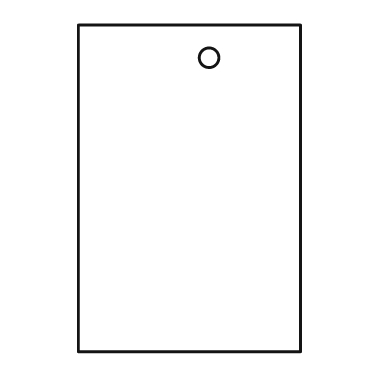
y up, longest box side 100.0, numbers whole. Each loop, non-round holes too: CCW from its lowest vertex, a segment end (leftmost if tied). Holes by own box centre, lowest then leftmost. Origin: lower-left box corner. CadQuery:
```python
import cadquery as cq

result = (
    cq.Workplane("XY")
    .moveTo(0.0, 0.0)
    .lineTo(68.0, 0.0)
    .lineTo(68.0, 100.0)
    .lineTo(0.0, 100.0)
    .close()
    .moveTo(40.0, 90.0)
    .circle(3.0)
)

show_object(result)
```